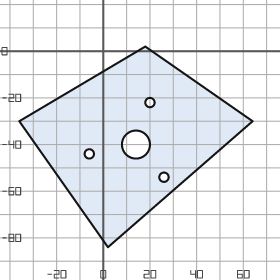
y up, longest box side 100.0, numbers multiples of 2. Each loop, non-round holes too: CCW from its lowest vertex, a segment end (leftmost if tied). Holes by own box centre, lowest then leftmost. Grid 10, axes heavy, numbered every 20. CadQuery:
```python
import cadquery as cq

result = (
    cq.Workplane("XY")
    .moveTo(2.0, -84.0)
    .lineTo(64.0, -30.0)
    .lineTo(18.0, 2.0)
    .lineTo(-36.0, -30.0)
    .close()
    .moveTo(26.0, -54.0)
    .circle(2.0)
    .moveTo(-6.0, -44.0)
    .circle(2.0)
    .moveTo(14.0, -40.0)
    .circle(6.0)
    .moveTo(20.0, -22.0)
    .circle(2.0)
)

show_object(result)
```